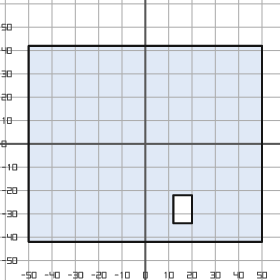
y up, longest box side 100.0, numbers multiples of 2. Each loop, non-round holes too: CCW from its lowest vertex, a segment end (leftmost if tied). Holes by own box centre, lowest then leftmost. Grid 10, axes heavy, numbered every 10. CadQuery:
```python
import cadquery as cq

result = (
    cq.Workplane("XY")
    .moveTo(-50.0, -42.0)
    .lineTo(50.0, -42.0)
    .lineTo(50.0, 42.0)
    .lineTo(-50.0, 42.0)
    .close()
    .moveTo(12.0, -34.0)
    .lineTo(20.0, -34.0)
    .lineTo(20.0, -22.0)
    .lineTo(12.0, -22.0)
    .close()
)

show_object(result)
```